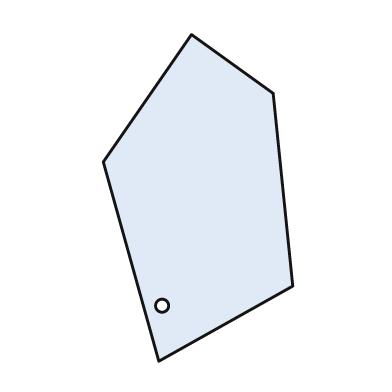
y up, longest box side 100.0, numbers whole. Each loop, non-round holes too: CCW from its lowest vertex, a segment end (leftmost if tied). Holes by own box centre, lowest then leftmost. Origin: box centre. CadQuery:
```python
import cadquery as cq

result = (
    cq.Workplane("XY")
    .moveTo(-12.0, -50.0)
    .lineTo(29.0, -27.0)
    .lineTo(23.0, 32.0)
    .lineTo(-2.0, 50.0)
    .lineTo(-29.0, 11.0)
    .close()
    .moveTo(-11.0, -33.0)
    .circle(2.0)
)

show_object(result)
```